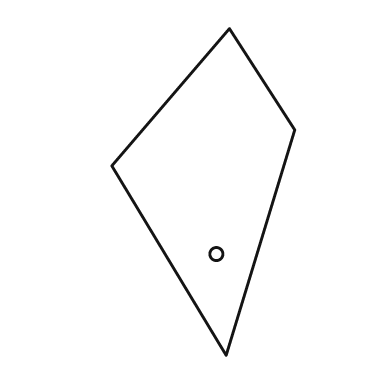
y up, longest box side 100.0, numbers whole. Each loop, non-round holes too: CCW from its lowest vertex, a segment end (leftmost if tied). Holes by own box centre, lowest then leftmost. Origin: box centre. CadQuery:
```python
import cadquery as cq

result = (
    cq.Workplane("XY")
    .moveTo(7.0, -50.0)
    .lineTo(28.0, 19.0)
    .lineTo(8.0, 50.0)
    .lineTo(-28.0, 8.0)
    .close()
    .moveTo(4.0, -19.0)
    .circle(2.0)
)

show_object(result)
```